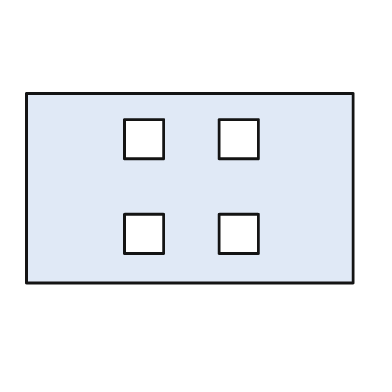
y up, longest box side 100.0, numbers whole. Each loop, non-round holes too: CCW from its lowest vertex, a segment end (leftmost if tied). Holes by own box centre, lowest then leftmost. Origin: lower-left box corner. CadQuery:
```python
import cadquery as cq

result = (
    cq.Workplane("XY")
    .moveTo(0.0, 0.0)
    .lineTo(100.0, 0.0)
    .lineTo(100.0, 58.0)
    .lineTo(0.0, 58.0)
    .close()
    .moveTo(30.0, 9.0)
    .lineTo(42.0, 9.0)
    .lineTo(42.0, 21.0)
    .lineTo(30.0, 21.0)
    .close()
    .moveTo(59.0, 9.0)
    .lineTo(71.0, 9.0)
    .lineTo(71.0, 21.0)
    .lineTo(59.0, 21.0)
    .close()
    .moveTo(30.0, 38.0)
    .lineTo(42.0, 38.0)
    .lineTo(42.0, 50.0)
    .lineTo(30.0, 50.0)
    .close()
    .moveTo(59.0, 38.0)
    .lineTo(71.0, 38.0)
    .lineTo(71.0, 50.0)
    .lineTo(59.0, 50.0)
    .close()
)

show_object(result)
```